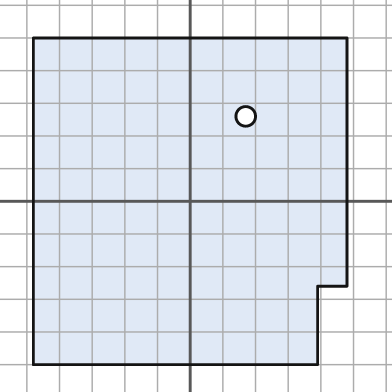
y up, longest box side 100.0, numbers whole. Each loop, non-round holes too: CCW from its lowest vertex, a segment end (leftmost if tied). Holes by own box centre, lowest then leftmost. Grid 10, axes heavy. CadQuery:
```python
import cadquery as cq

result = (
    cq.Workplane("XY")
    .moveTo(-48.0, -50.0)
    .lineTo(39.0, -50.0)
    .lineTo(39.0, -26.0)
    .lineTo(48.0, -26.0)
    .lineTo(48.0, 50.0)
    .lineTo(-48.0, 50.0)
    .close()
    .moveTo(17.0, 26.0)
    .circle(3.0)
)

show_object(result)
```